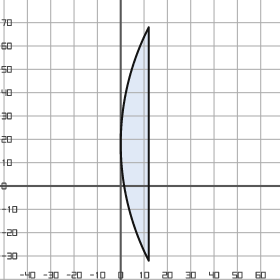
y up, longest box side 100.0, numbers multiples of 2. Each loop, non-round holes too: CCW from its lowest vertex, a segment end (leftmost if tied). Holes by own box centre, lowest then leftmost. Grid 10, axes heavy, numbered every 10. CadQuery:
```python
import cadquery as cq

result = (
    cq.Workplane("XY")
    .moveTo(12.0, -32.0)
    .lineTo(12.0, 68.0)
    .threePointArc((0.0, 18.0), (12.0, -32.0))
    .close()
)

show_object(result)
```